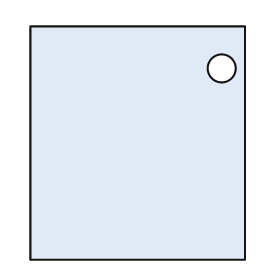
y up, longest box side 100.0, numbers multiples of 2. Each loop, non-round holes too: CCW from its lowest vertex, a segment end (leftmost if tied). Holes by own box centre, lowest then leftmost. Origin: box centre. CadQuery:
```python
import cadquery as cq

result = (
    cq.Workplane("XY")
    .moveTo(-46.0, -50.0)
    .lineTo(46.0, -50.0)
    .lineTo(46.0, 50.0)
    .lineTo(-46.0, 50.0)
    .close()
    .moveTo(36.0, 32.0)
    .circle(6.0)
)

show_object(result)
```